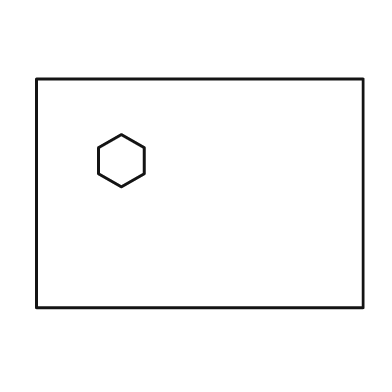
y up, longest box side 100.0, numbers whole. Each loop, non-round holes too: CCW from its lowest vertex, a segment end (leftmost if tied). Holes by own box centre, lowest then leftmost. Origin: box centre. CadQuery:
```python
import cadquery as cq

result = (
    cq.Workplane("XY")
    .moveTo(-50.0, -35.0)
    .lineTo(50.0, -35.0)
    .lineTo(50.0, 35.0)
    .lineTo(-50.0, 35.0)
    .close()
    .moveTo(-24.0, 2.0)
    .lineTo(-17.0, 6.0)
    .lineTo(-17.0, 14.0)
    .lineTo(-24.0, 18.0)
    .lineTo(-31.0, 14.0)
    .lineTo(-31.0, 6.0)
    .close()
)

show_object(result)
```